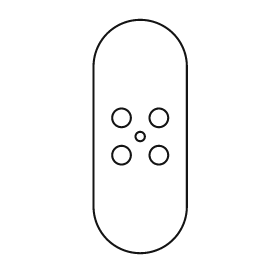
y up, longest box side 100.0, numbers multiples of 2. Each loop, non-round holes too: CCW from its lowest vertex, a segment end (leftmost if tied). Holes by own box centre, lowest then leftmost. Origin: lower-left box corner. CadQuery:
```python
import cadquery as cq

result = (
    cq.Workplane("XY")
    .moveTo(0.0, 20.0)
    .threePointArc((20.0, 0.0), (40.0, 20.0))
    .lineTo(40.0, 80.0)
    .threePointArc((20.0, 100.0), (0.0, 80.0))
    .close()
    .moveTo(12.0, 42.0)
    .circle(4.0)
    .moveTo(28.0, 42.0)
    .circle(4.0)
    .moveTo(20.0, 50.0)
    .circle(2.0)
    .moveTo(12.0, 58.0)
    .circle(4.0)
    .moveTo(28.0, 58.0)
    .circle(4.0)
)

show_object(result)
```